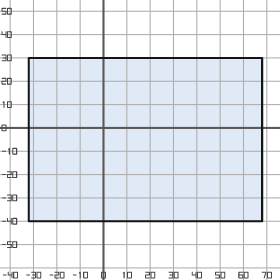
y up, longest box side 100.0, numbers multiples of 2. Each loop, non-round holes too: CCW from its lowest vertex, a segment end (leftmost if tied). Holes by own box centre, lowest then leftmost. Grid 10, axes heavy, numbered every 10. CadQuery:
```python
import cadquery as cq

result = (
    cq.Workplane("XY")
    .moveTo(-32.0, -40.0)
    .lineTo(68.0, -40.0)
    .lineTo(68.0, 30.0)
    .lineTo(-32.0, 30.0)
    .close()
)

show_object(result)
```